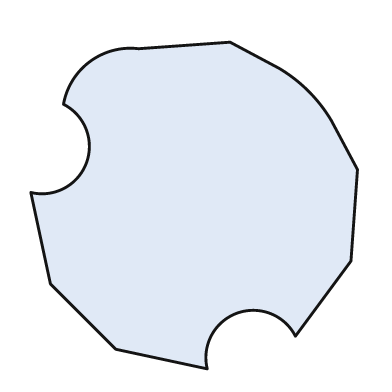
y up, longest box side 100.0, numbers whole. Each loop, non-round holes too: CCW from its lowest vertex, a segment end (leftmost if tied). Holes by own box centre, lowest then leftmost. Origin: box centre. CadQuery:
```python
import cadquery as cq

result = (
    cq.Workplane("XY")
    .moveTo(4.0, -50.0)
    .threePointArc((13.0, -33.0), (31.0, -40.0))
    .lineTo(48.0, -17.0)
    .lineTo(50.0, 11.0)
    .lineTo(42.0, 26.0)
    .threePointArc((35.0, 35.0), (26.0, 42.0))
    .lineTo(11.0, 50.0)
    .lineTo(-17.0, 48.0)
    .threePointArc((-32.0, 44.0), (-40.0, 31.0))
    .threePointArc((-33.0, 13.0), (-50.0, 4.0))
    .lineTo(-44.0, -24.0)
    .lineTo(-24.0, -44.0)
    .close()
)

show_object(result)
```